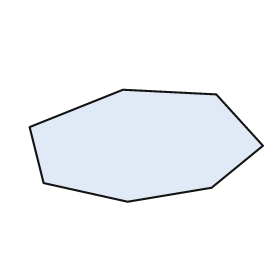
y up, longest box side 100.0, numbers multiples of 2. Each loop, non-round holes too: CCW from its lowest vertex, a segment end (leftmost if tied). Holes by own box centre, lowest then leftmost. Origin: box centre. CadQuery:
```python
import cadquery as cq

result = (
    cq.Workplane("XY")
    .moveTo(-8.0, -24.0)
    .lineTo(28.0, -18.0)
    .lineTo(50.0, 0.0)
    .lineTo(30.0, 22.0)
    .lineTo(-10.0, 24.0)
    .lineTo(-50.0, 8.0)
    .lineTo(-44.0, -16.0)
    .close()
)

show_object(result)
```